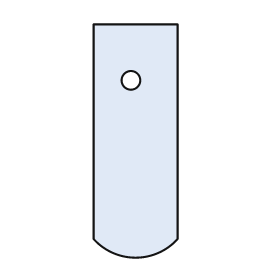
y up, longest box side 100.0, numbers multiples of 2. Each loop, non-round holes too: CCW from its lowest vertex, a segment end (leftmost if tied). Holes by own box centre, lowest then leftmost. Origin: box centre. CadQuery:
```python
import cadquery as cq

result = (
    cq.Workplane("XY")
    .moveTo(-18.0, -42.0)
    .threePointArc((0.0, -50.0), (18.0, -42.0))
    .lineTo(18.0, 50.0)
    .lineTo(-18.0, 50.0)
    .close()
    .moveTo(-2.0, 26.0)
    .circle(4.0)
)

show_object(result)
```